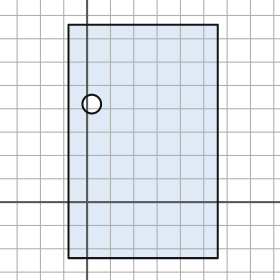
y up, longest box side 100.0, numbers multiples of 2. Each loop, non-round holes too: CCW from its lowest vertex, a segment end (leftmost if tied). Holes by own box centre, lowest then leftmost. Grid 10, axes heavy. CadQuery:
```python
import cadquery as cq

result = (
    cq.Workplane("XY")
    .moveTo(-8.0, -24.0)
    .lineTo(56.0, -24.0)
    .lineTo(56.0, 76.0)
    .lineTo(-8.0, 76.0)
    .close()
    .moveTo(2.0, 42.0)
    .circle(4.0)
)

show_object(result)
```